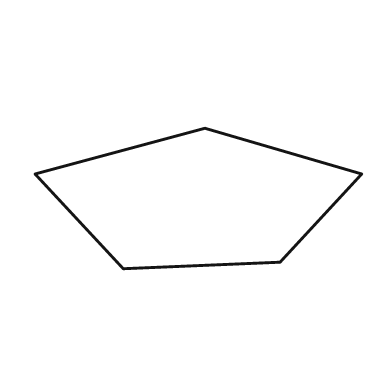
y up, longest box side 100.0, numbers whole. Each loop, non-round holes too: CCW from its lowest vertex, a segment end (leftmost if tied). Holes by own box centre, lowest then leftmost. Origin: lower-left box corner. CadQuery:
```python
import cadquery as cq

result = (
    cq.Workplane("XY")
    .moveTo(27.0, 0.0)
    .lineTo(75.0, 2.0)
    .lineTo(100.0, 29.0)
    .lineTo(52.0, 43.0)
    .lineTo(0.0, 29.0)
    .close()
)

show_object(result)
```